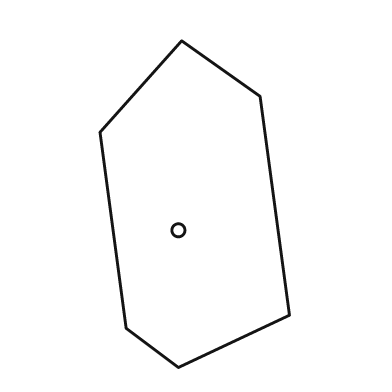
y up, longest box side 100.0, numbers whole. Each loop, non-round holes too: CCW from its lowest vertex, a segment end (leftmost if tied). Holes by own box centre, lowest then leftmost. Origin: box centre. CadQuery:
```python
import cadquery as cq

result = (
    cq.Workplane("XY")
    .moveTo(-5.0, -50.0)
    .lineTo(29.0, -34.0)
    .lineTo(20.0, 33.0)
    .lineTo(-4.0, 50.0)
    .lineTo(-29.0, 22.0)
    .lineTo(-21.0, -38.0)
    .close()
    .moveTo(-5.0, -8.0)
    .circle(2.0)
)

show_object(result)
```